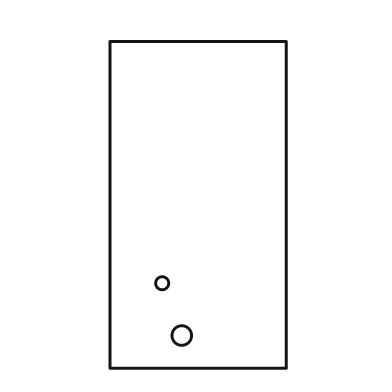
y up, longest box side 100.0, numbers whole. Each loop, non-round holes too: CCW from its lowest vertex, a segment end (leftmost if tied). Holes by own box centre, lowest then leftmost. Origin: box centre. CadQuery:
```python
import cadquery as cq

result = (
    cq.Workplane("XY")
    .moveTo(-27.0, -50.0)
    .lineTo(27.0, -50.0)
    .lineTo(27.0, 50.0)
    .lineTo(-27.0, 50.0)
    .close()
    .moveTo(-5.0, -40.0)
    .circle(3.0)
    .moveTo(-11.0, -24.0)
    .circle(2.0)
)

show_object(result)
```